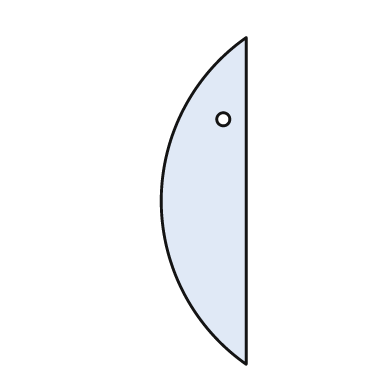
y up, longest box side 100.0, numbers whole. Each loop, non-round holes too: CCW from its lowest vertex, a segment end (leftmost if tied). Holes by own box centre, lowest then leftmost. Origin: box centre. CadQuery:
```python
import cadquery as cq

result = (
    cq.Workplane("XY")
    .moveTo(13.0, -50.0)
    .lineTo(13.0, 50.0)
    .threePointArc((-13.0, 0.0), (13.0, -50.0))
    .close()
    .moveTo(6.0, 25.0)
    .circle(2.0)
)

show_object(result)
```